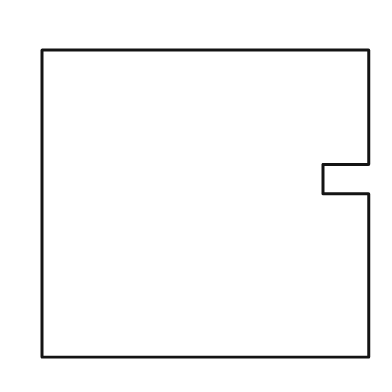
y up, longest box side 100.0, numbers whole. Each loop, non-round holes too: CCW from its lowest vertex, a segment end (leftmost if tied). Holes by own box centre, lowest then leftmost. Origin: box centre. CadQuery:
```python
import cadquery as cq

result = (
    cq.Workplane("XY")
    .moveTo(-50.0, -47.0)
    .lineTo(50.0, -47.0)
    .lineTo(50.0, 3.0)
    .lineTo(36.0, 3.0)
    .lineTo(36.0, 12.0)
    .lineTo(50.0, 12.0)
    .lineTo(50.0, 47.0)
    .lineTo(-50.0, 47.0)
    .close()
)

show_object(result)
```